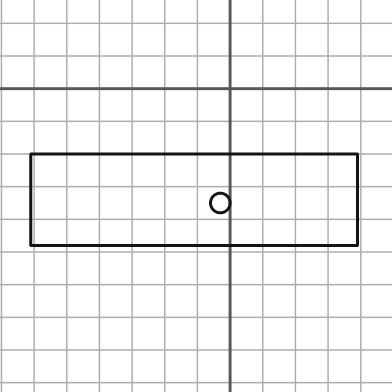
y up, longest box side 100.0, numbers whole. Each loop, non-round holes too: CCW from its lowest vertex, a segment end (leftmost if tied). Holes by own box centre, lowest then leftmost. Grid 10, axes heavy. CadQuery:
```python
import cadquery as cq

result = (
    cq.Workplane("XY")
    .moveTo(-61.0, -48.0)
    .lineTo(39.0, -48.0)
    .lineTo(39.0, -20.0)
    .lineTo(-61.0, -20.0)
    .close()
    .moveTo(-3.0, -35.0)
    .circle(3.0)
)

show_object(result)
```